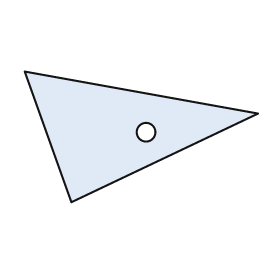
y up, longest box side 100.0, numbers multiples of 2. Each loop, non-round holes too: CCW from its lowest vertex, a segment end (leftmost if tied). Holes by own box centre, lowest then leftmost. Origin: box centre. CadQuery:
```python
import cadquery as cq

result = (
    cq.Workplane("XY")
    .moveTo(-30.0, -28.0)
    .lineTo(50.0, 10.0)
    .lineTo(-50.0, 28.0)
    .close()
    .moveTo(2.0, 2.0)
    .circle(4.0)
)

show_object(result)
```